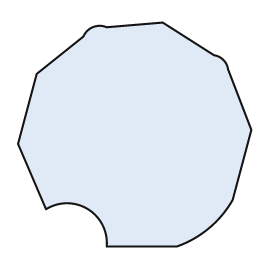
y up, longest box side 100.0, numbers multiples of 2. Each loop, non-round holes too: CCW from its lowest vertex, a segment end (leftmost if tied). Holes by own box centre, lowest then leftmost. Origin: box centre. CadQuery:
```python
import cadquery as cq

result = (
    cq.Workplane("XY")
    .moveTo(-12.0, -48.0)
    .lineTo(18.0, -48.0)
    .threePointArc((32.0, -40.0), (42.0, -28.0))
    .lineTo(50.0, 2.0)
    .lineTo(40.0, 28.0)
    .threePointArc((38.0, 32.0), (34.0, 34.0))
    .lineTo(12.0, 48.0)
    .lineTo(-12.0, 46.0)
    .threePointArc((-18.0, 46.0), (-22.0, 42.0))
    .lineTo(-42.0, 26.0)
    .lineTo(-50.0, -4.0)
    .lineTo(-38.0, -32.0)
    .threePointArc((-20.0, -32.0), (-12.0, -48.0))
    .close()
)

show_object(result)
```